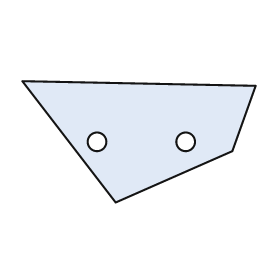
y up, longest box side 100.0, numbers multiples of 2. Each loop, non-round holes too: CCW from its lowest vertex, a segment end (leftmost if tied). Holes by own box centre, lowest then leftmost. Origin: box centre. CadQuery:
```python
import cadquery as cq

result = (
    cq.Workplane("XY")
    .moveTo(-10.0, -26.0)
    .lineTo(40.0, -4.0)
    .lineTo(50.0, 24.0)
    .lineTo(-50.0, 26.0)
    .close()
    .moveTo(-18.0, 0.0)
    .circle(4.0)
    .moveTo(20.0, 0.0)
    .circle(4.0)
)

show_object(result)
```